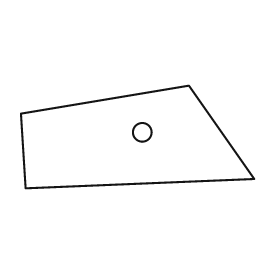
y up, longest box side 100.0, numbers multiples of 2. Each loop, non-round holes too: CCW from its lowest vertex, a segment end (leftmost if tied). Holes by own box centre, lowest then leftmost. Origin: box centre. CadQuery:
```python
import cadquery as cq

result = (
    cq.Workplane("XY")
    .moveTo(-48.0, -22.0)
    .lineTo(50.0, -18.0)
    .lineTo(22.0, 22.0)
    .lineTo(-50.0, 10.0)
    .close()
    .moveTo(2.0, 2.0)
    .circle(4.0)
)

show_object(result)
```